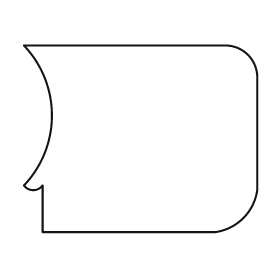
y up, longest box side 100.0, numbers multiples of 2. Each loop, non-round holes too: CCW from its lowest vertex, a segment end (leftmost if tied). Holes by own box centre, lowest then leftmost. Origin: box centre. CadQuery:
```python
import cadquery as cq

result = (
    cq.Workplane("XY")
    .moveTo(-42.0, -40.0)
    .lineTo(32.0, -40.0)
    .threePointArc((44.0, -34.0), (50.0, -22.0))
    .lineTo(50.0, 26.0)
    .threePointArc((46.0, 36.0), (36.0, 40.0))
    .lineTo(-50.0, 40.0)
    .threePointArc((-38.0, 10.0), (-50.0, -20.0))
    .threePointArc((-46.0, -22.0), (-42.0, -20.0))
    .close()
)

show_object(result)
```